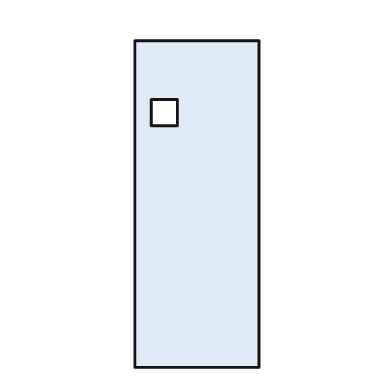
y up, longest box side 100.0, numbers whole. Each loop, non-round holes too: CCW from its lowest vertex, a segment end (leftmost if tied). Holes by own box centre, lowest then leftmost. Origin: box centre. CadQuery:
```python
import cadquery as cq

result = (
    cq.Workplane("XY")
    .moveTo(-19.0, -50.0)
    .lineTo(19.0, -50.0)
    .lineTo(19.0, 50.0)
    .lineTo(-19.0, 50.0)
    .close()
    .moveTo(-14.0, 24.0)
    .lineTo(-6.0, 24.0)
    .lineTo(-6.0, 32.0)
    .lineTo(-14.0, 32.0)
    .close()
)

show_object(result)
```